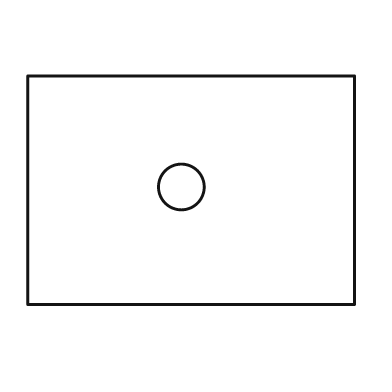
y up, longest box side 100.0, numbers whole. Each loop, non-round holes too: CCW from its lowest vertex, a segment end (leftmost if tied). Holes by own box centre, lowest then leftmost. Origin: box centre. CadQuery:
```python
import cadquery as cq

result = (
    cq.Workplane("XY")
    .moveTo(-50.0, -35.0)
    .lineTo(50.0, -35.0)
    .lineTo(50.0, 35.0)
    .lineTo(-50.0, 35.0)
    .close()
    .moveTo(-3.0, 1.0)
    .circle(7.0)
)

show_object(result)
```